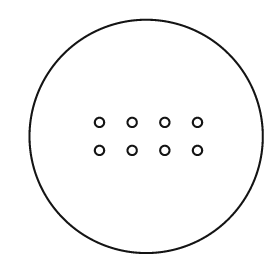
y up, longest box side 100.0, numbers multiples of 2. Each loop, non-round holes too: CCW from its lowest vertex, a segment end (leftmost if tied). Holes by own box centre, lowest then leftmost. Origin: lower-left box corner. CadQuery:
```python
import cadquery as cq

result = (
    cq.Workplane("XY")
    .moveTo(50.0, 50.0)
    .circle(50.0)
    .moveTo(30.0, 44.0)
    .circle(2.0)
    .moveTo(44.0, 44.0)
    .circle(2.0)
    .moveTo(58.0, 44.0)
    .circle(2.0)
    .moveTo(72.0, 44.0)
    .circle(2.0)
    .moveTo(30.0, 56.0)
    .circle(2.0)
    .moveTo(44.0, 56.0)
    .circle(2.0)
    .moveTo(58.0, 56.0)
    .circle(2.0)
    .moveTo(72.0, 56.0)
    .circle(2.0)
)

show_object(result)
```